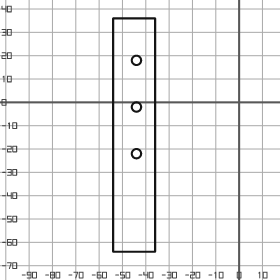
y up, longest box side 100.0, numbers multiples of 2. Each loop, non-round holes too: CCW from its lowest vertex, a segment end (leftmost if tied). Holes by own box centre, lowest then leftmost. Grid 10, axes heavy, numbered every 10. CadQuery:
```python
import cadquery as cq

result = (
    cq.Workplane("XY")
    .moveTo(-54.0, -64.0)
    .lineTo(-36.0, -64.0)
    .lineTo(-36.0, 36.0)
    .lineTo(-54.0, 36.0)
    .close()
    .moveTo(-44.0, -22.0)
    .circle(2.0)
    .moveTo(-44.0, -2.0)
    .circle(2.0)
    .moveTo(-44.0, 18.0)
    .circle(2.0)
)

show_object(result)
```